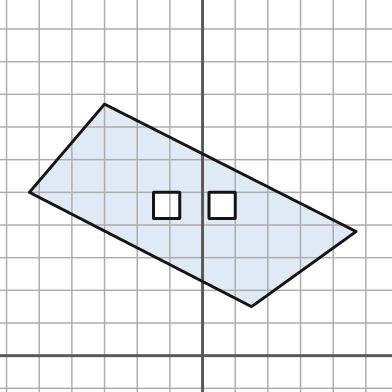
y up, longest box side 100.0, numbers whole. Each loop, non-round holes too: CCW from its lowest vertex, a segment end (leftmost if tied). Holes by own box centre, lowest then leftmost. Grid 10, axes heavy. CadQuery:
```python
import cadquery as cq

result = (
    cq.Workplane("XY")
    .moveTo(15.0, 15.0)
    .lineTo(47.0, 38.0)
    .lineTo(-30.0, 77.0)
    .lineTo(-53.0, 50.0)
    .close()
    .moveTo(-15.0, 42.0)
    .lineTo(-7.0, 42.0)
    .lineTo(-7.0, 50.0)
    .lineTo(-15.0, 50.0)
    .close()
    .moveTo(2.0, 42.0)
    .lineTo(10.0, 42.0)
    .lineTo(10.0, 50.0)
    .lineTo(2.0, 50.0)
    .close()
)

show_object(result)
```